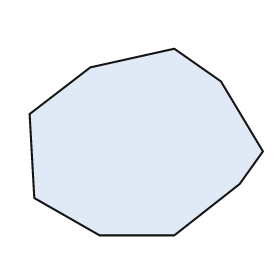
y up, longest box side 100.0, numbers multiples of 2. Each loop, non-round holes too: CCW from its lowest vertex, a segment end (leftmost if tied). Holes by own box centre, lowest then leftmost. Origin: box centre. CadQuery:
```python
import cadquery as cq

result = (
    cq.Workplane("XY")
    .moveTo(-20.0, -40.0)
    .lineTo(12.0, -40.0)
    .lineTo(40.0, -18.0)
    .lineTo(50.0, -4.0)
    .lineTo(32.0, 26.0)
    .lineTo(12.0, 40.0)
    .lineTo(-24.0, 32.0)
    .lineTo(-50.0, 12.0)
    .lineTo(-48.0, -24.0)
    .close()
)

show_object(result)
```